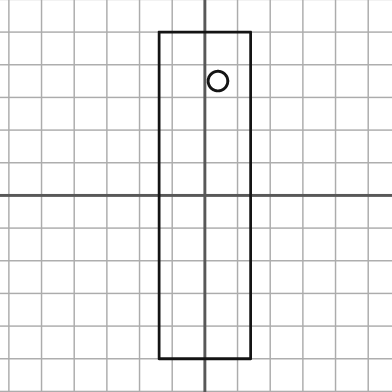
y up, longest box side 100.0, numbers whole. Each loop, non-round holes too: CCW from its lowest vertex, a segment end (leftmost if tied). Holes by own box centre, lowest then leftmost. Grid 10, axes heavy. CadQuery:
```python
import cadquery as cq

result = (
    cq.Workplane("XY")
    .moveTo(-14.0, -50.0)
    .lineTo(14.0, -50.0)
    .lineTo(14.0, 50.0)
    .lineTo(-14.0, 50.0)
    .close()
    .moveTo(4.0, 35.0)
    .circle(3.0)
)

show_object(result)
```